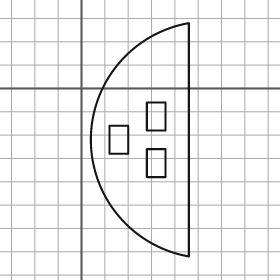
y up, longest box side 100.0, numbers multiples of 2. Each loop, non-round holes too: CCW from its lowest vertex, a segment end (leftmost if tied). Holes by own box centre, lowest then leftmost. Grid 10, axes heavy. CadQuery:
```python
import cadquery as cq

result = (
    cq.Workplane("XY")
    .moveTo(46.0, -72.0)
    .lineTo(46.0, 28.0)
    .threePointArc((4.0, -22.0), (46.0, -72.0))
    .close()
    .moveTo(28.0, -38.0)
    .lineTo(36.0, -38.0)
    .lineTo(36.0, -26.0)
    .lineTo(28.0, -26.0)
    .close()
    .moveTo(12.0, -28.0)
    .lineTo(20.0, -28.0)
    .lineTo(20.0, -16.0)
    .lineTo(12.0, -16.0)
    .close()
    .moveTo(28.0, -18.0)
    .lineTo(36.0, -18.0)
    .lineTo(36.0, -6.0)
    .lineTo(28.0, -6.0)
    .close()
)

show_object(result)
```